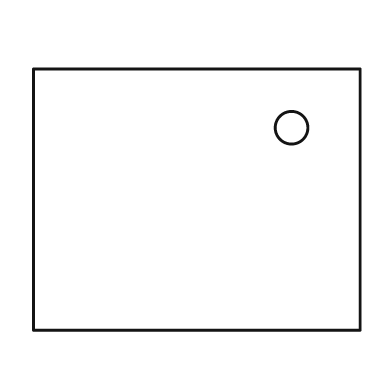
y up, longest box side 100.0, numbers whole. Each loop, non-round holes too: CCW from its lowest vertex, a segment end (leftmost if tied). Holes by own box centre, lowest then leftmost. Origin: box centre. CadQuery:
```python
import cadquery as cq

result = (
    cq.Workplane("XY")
    .moveTo(-50.0, -40.0)
    .lineTo(50.0, -40.0)
    .lineTo(50.0, 40.0)
    .lineTo(-50.0, 40.0)
    .close()
    .moveTo(29.0, 22.0)
    .circle(5.0)
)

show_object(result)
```